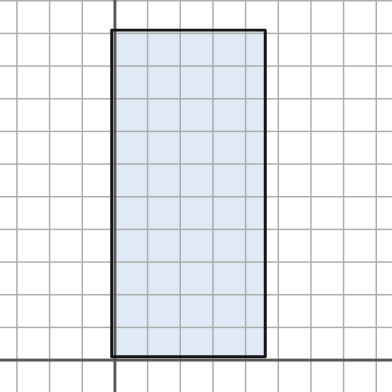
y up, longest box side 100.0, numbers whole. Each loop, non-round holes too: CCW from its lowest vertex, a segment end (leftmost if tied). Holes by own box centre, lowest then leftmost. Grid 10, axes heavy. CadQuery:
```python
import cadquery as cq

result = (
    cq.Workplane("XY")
    .moveTo(-1.0, 1.0)
    .lineTo(46.0, 1.0)
    .lineTo(46.0, 101.0)
    .lineTo(-1.0, 101.0)
    .close()
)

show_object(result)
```